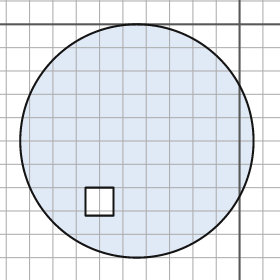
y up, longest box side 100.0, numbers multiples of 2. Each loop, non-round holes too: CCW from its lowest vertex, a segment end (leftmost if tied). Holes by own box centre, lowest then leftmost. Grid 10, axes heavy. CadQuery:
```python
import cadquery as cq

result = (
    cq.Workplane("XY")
    .moveTo(-44.0, -50.0)
    .circle(50.0)
    .moveTo(-66.0, -82.0)
    .lineTo(-54.0, -82.0)
    .lineTo(-54.0, -70.0)
    .lineTo(-66.0, -70.0)
    .close()
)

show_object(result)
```